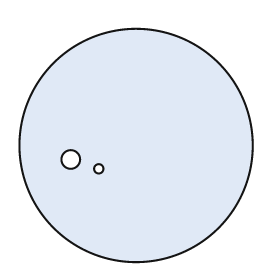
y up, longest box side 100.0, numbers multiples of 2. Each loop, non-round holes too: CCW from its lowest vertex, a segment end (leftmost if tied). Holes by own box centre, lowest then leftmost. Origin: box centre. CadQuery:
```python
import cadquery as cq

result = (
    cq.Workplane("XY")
    .moveTo(0.0, 0.0)
    .circle(50.0)
    .moveTo(-16.0, -10.0)
    .circle(2.0)
    .moveTo(-28.0, -6.0)
    .circle(4.0)
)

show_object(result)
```